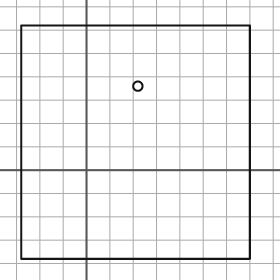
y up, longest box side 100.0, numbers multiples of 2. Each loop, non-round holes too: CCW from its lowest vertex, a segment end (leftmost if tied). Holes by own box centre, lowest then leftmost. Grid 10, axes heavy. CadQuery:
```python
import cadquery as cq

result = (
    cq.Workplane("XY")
    .moveTo(-28.0, -38.0)
    .lineTo(70.0, -38.0)
    .lineTo(70.0, 62.0)
    .lineTo(-28.0, 62.0)
    .close()
    .moveTo(22.0, 36.0)
    .circle(2.0)
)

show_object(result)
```